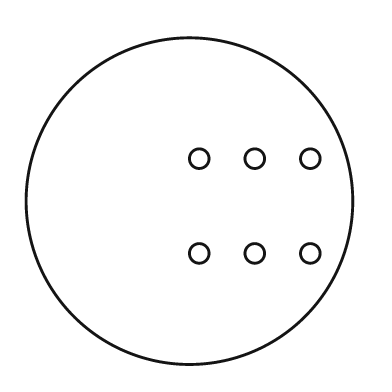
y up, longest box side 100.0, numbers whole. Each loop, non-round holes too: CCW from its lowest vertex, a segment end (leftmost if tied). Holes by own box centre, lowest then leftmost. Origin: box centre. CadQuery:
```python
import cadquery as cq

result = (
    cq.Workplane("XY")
    .moveTo(0.0, 0.0)
    .circle(50.0)
    .moveTo(3.0, -16.0)
    .circle(3.0)
    .moveTo(20.0, -16.0)
    .circle(3.0)
    .moveTo(37.0, -16.0)
    .circle(3.0)
    .moveTo(3.0, 13.0)
    .circle(3.0)
    .moveTo(20.0, 13.0)
    .circle(3.0)
    .moveTo(37.0, 13.0)
    .circle(3.0)
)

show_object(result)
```